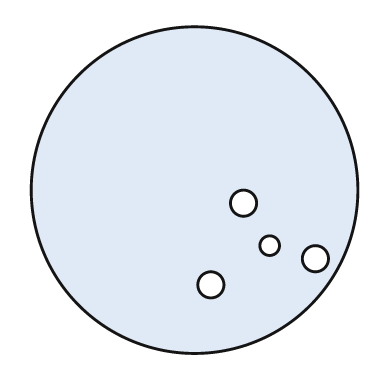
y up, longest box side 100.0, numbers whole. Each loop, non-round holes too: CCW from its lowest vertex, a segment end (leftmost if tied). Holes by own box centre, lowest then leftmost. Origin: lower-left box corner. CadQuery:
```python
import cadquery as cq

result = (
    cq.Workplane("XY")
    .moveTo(50.0, 50.0)
    .circle(50.0)
    .moveTo(55.0, 21.0)
    .circle(4.0)
    .moveTo(87.0, 29.0)
    .circle(4.0)
    .moveTo(73.0, 33.0)
    .circle(3.0)
    .moveTo(65.0, 46.0)
    .circle(4.0)
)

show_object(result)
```